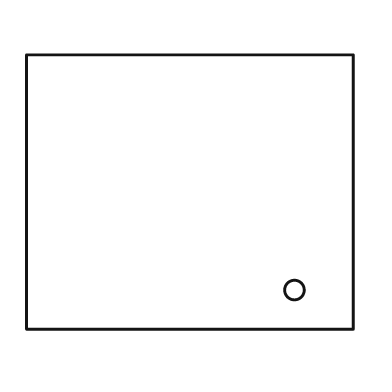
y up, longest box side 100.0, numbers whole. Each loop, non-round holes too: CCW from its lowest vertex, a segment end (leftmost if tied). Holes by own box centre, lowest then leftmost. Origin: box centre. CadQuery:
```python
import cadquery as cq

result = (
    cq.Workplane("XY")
    .moveTo(-50.0, -42.0)
    .lineTo(50.0, -42.0)
    .lineTo(50.0, 42.0)
    .lineTo(-50.0, 42.0)
    .close()
    .moveTo(32.0, -30.0)
    .circle(3.0)
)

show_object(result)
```